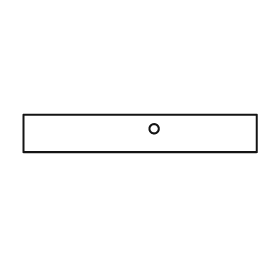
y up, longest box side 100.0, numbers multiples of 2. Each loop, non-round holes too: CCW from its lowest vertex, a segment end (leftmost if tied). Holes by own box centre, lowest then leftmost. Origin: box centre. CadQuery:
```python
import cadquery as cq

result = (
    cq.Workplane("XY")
    .moveTo(-50.0, -8.0)
    .lineTo(50.0, -8.0)
    .lineTo(50.0, 8.0)
    .lineTo(-50.0, 8.0)
    .close()
    .moveTo(6.0, 2.0)
    .circle(2.0)
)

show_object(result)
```